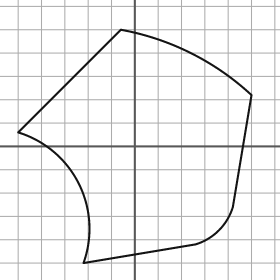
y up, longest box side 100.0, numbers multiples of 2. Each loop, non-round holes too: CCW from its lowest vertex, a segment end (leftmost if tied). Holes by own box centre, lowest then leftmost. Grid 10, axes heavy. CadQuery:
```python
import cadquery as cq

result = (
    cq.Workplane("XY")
    .moveTo(-22.0, -50.0)
    .lineTo(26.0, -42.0)
    .threePointArc((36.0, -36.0), (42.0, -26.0))
    .lineTo(50.0, 22.0)
    .threePointArc((24.0, 40.0), (-6.0, 50.0))
    .lineTo(-50.0, 6.0)
    .threePointArc((-24.0, -16.0), (-22.0, -50.0))
    .close()
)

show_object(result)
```